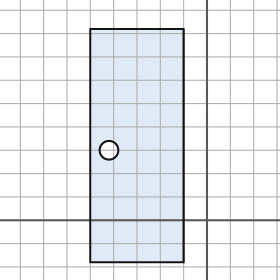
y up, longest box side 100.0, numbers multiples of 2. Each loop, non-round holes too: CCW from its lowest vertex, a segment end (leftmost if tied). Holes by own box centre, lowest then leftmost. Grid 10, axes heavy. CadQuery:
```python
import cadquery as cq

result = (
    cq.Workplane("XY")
    .moveTo(-50.0, -18.0)
    .lineTo(-10.0, -18.0)
    .lineTo(-10.0, 82.0)
    .lineTo(-50.0, 82.0)
    .close()
    .moveTo(-42.0, 30.0)
    .circle(4.0)
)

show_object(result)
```